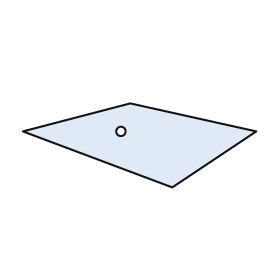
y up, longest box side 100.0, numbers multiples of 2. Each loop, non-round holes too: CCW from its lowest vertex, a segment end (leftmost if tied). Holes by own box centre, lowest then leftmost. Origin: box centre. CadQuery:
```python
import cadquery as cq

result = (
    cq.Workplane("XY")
    .moveTo(14.0, -18.0)
    .lineTo(50.0, 6.0)
    .lineTo(-4.0, 18.0)
    .lineTo(-50.0, 6.0)
    .close()
    .moveTo(-8.0, 6.0)
    .circle(2.0)
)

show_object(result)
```